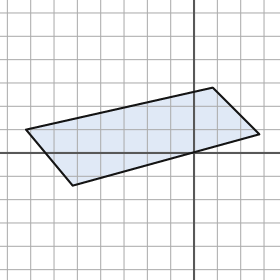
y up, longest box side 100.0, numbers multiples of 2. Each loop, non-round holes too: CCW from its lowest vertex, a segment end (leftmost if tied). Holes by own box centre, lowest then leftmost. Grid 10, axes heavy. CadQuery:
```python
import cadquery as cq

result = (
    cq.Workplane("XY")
    .moveTo(-52.0, -14.0)
    .lineTo(28.0, 8.0)
    .lineTo(8.0, 28.0)
    .lineTo(-72.0, 10.0)
    .close()
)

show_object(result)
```